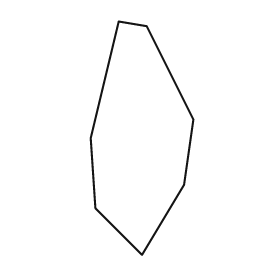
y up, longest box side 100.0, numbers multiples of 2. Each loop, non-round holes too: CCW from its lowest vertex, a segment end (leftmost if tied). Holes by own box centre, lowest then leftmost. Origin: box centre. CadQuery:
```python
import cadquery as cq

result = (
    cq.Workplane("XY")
    .moveTo(0.0, -50.0)
    .lineTo(18.0, -20.0)
    .lineTo(22.0, 8.0)
    .lineTo(2.0, 48.0)
    .lineTo(-10.0, 50.0)
    .lineTo(-22.0, 0.0)
    .lineTo(-20.0, -30.0)
    .close()
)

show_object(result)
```